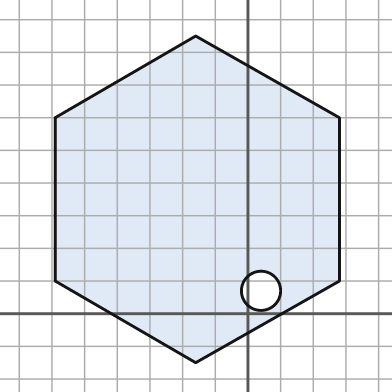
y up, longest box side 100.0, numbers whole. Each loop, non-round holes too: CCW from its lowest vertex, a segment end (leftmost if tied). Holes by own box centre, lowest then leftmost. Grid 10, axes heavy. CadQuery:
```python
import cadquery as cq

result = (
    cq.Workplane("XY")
    .moveTo(-16.0, -15.0)
    .lineTo(28.0, 10.0)
    .lineTo(28.0, 60.0)
    .lineTo(-16.0, 85.0)
    .lineTo(-59.0, 60.0)
    .lineTo(-59.0, 10.0)
    .close()
    .moveTo(4.0, 7.0)
    .circle(6.0)
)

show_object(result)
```